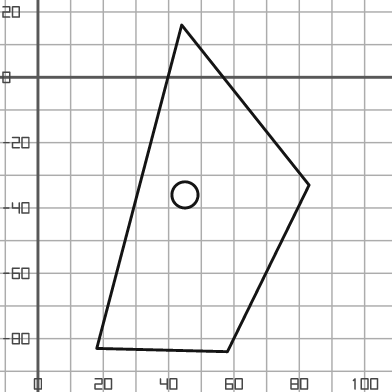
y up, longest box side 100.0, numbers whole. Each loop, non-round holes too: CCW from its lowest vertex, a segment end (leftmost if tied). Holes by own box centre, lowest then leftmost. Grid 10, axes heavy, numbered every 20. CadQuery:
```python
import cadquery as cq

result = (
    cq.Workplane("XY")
    .moveTo(58.0, -84.0)
    .lineTo(83.0, -33.0)
    .lineTo(44.0, 16.0)
    .lineTo(18.0, -83.0)
    .close()
    .moveTo(45.0, -36.0)
    .circle(4.0)
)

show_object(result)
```